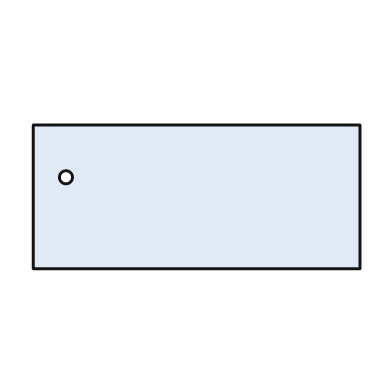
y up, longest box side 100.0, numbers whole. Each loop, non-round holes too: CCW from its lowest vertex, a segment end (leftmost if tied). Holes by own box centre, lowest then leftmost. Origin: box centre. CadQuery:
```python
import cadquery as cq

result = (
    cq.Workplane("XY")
    .moveTo(-50.0, -22.0)
    .lineTo(50.0, -22.0)
    .lineTo(50.0, 22.0)
    .lineTo(-50.0, 22.0)
    .close()
    .moveTo(-40.0, 6.0)
    .circle(2.0)
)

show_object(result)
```